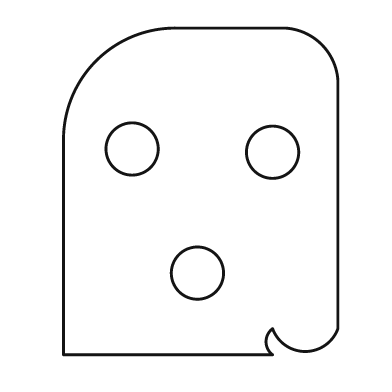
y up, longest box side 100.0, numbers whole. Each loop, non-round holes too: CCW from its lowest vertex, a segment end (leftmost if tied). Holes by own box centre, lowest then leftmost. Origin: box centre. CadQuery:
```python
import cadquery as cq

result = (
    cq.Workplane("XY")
    .moveTo(-42.0, -50.0)
    .lineTo(22.0, -50.0)
    .threePointArc((20.0, -46.0), (22.0, -42.0))
    .threePointArc((32.0, -49.0), (42.0, -42.0))
    .lineTo(42.0, 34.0)
    .threePointArc((37.0, 45.0), (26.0, 50.0))
    .lineTo(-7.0, 50.0)
    .threePointArc((-32.0, 40.0), (-42.0, 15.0))
    .close()
    .moveTo(-1.0, -25.0)
    .circle(8.0)
    .moveTo(22.0, 12.0)
    .circle(8.0)
    .moveTo(-21.0, 13.0)
    .circle(8.0)
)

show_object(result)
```